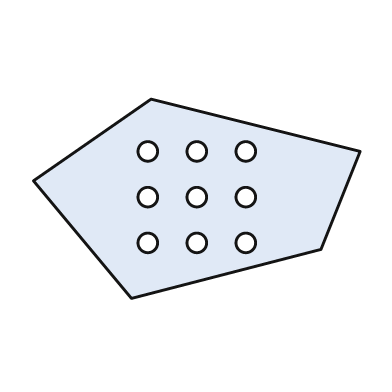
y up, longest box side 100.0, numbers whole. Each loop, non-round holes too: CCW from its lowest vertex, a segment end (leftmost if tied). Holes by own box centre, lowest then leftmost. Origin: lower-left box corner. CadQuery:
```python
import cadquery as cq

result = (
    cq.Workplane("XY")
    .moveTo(30.0, 0.0)
    .lineTo(88.0, 15.0)
    .lineTo(100.0, 45.0)
    .lineTo(36.0, 61.0)
    .lineTo(0.0, 36.0)
    .close()
    .moveTo(35.0, 17.0)
    .circle(3.0)
    .moveTo(50.0, 17.0)
    .circle(3.0)
    .moveTo(65.0, 17.0)
    .circle(3.0)
    .moveTo(35.0, 31.0)
    .circle(3.0)
    .moveTo(50.0, 31.0)
    .circle(3.0)
    .moveTo(65.0, 31.0)
    .circle(3.0)
    .moveTo(35.0, 45.0)
    .circle(3.0)
    .moveTo(50.0, 45.0)
    .circle(3.0)
    .moveTo(65.0, 45.0)
    .circle(3.0)
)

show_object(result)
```